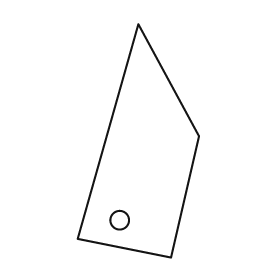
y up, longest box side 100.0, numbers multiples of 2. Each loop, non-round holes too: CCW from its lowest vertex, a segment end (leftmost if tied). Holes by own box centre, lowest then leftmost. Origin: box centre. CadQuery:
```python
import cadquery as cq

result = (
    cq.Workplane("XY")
    .moveTo(14.0, -50.0)
    .lineTo(26.0, 2.0)
    .lineTo(0.0, 50.0)
    .lineTo(-26.0, -42.0)
    .close()
    .moveTo(-8.0, -34.0)
    .circle(4.0)
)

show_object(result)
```